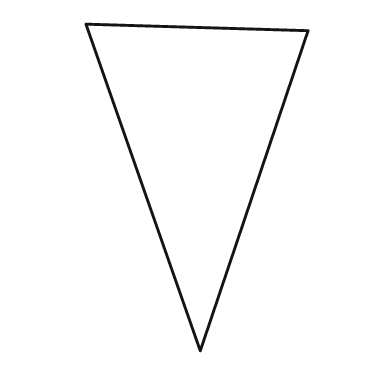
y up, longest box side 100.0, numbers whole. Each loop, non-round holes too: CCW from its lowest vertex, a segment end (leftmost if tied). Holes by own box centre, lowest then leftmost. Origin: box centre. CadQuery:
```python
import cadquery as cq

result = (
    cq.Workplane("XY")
    .moveTo(1.0, -50.0)
    .lineTo(34.0, 48.0)
    .lineTo(-34.0, 50.0)
    .close()
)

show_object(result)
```